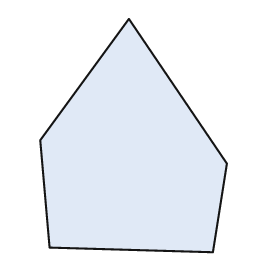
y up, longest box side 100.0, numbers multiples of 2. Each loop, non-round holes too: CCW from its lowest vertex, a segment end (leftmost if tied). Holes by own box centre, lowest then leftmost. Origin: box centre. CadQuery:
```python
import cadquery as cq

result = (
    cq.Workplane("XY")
    .moveTo(34.0, -50.0)
    .lineTo(40.0, -12.0)
    .lineTo(-2.0, 50.0)
    .lineTo(-40.0, -2.0)
    .lineTo(-36.0, -48.0)
    .close()
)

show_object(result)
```